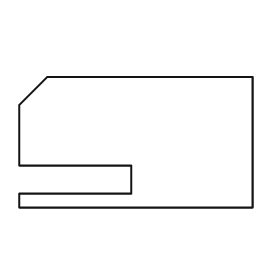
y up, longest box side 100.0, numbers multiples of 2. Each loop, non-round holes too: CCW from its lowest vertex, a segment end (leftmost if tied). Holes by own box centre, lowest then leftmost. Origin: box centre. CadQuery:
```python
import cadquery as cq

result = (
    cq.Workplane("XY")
    .moveTo(-50.0, -28.0)
    .lineTo(50.0, -28.0)
    .lineTo(50.0, 28.0)
    .lineTo(-38.0, 28.0)
    .lineTo(-50.0, 16.0)
    .lineTo(-50.0, -10.0)
    .lineTo(-2.0, -10.0)
    .lineTo(-2.0, -22.0)
    .lineTo(-50.0, -22.0)
    .close()
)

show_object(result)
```